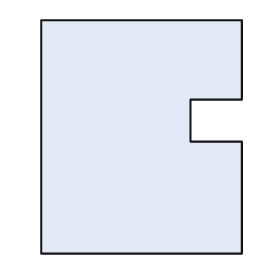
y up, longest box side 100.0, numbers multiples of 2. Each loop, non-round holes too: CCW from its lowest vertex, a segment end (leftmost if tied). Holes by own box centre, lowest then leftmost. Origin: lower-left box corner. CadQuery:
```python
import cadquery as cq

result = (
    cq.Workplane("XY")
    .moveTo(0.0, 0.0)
    .lineTo(86.0, 0.0)
    .lineTo(86.0, 48.0)
    .lineTo(64.0, 48.0)
    .lineTo(64.0, 66.0)
    .lineTo(86.0, 66.0)
    .lineTo(86.0, 100.0)
    .lineTo(0.0, 100.0)
    .close()
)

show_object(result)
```